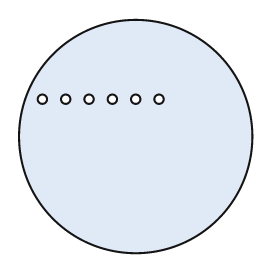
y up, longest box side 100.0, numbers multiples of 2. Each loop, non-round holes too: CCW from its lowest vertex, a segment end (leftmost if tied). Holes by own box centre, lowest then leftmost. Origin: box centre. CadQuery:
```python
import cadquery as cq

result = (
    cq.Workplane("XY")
    .moveTo(0.0, 0.0)
    .circle(50.0)
    .moveTo(-40.0, 16.0)
    .circle(2.0)
    .moveTo(-30.0, 16.0)
    .circle(2.0)
    .moveTo(-20.0, 16.0)
    .circle(2.0)
    .moveTo(-10.0, 16.0)
    .circle(2.0)
    .moveTo(0.0, 16.0)
    .circle(2.0)
    .moveTo(10.0, 16.0)
    .circle(2.0)
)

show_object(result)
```